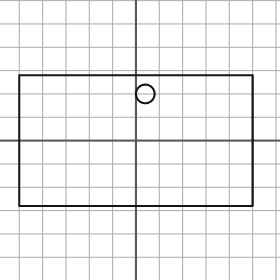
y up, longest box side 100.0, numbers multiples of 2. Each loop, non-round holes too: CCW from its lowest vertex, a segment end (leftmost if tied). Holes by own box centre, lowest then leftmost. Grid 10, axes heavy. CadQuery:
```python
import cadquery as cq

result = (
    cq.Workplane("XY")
    .moveTo(-50.0, -28.0)
    .lineTo(50.0, -28.0)
    .lineTo(50.0, 28.0)
    .lineTo(-50.0, 28.0)
    .close()
    .moveTo(4.0, 20.0)
    .circle(4.0)
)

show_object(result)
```